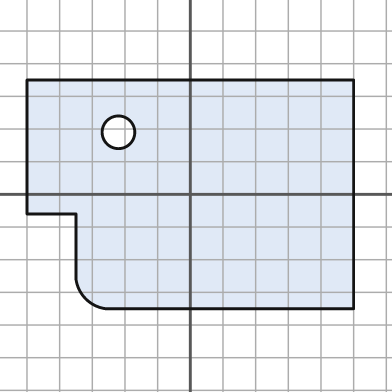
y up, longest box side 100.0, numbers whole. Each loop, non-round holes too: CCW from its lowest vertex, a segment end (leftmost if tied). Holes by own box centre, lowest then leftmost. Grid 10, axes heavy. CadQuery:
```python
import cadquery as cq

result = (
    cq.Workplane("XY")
    .moveTo(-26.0, -35.0)
    .lineTo(50.0, -35.0)
    .lineTo(50.0, 35.0)
    .lineTo(-50.0, 35.0)
    .lineTo(-50.0, -6.0)
    .lineTo(-35.0, -6.0)
    .lineTo(-35.0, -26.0)
    .threePointArc((-32.0, -32.0), (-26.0, -35.0))
    .close()
    .moveTo(-22.0, 19.0)
    .circle(5.0)
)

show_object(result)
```